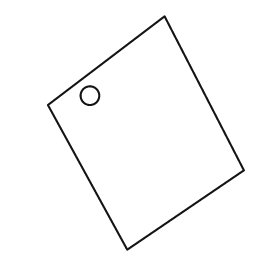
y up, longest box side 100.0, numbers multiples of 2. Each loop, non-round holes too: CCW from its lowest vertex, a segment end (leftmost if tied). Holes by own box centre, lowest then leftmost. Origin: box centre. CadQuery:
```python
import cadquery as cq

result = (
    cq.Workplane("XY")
    .moveTo(-8.0, -50.0)
    .lineTo(42.0, -16.0)
    .lineTo(8.0, 50.0)
    .lineTo(-42.0, 12.0)
    .close()
    .moveTo(-24.0, 16.0)
    .circle(4.0)
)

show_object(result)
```